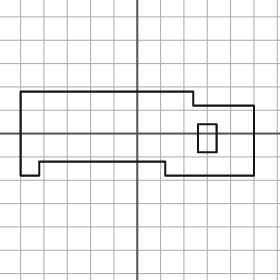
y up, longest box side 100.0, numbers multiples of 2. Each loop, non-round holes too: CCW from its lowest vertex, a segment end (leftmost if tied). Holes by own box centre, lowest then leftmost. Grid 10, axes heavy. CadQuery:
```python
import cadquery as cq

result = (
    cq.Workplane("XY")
    .moveTo(-50.0, -18.0)
    .lineTo(-42.0, -18.0)
    .lineTo(-42.0, -12.0)
    .lineTo(12.0, -12.0)
    .lineTo(12.0, -18.0)
    .lineTo(50.0, -18.0)
    .lineTo(50.0, 12.0)
    .lineTo(24.0, 12.0)
    .lineTo(24.0, 18.0)
    .lineTo(-50.0, 18.0)
    .close()
    .moveTo(26.0, -8.0)
    .lineTo(34.0, -8.0)
    .lineTo(34.0, 4.0)
    .lineTo(26.0, 4.0)
    .close()
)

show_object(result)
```